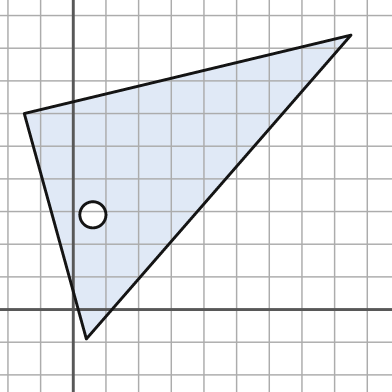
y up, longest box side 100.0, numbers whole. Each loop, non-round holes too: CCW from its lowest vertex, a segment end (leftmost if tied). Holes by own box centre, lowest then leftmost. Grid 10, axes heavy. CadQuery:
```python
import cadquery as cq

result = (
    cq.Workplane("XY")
    .moveTo(4.0, -9.0)
    .lineTo(85.0, 84.0)
    .lineTo(-15.0, 60.0)
    .close()
    .moveTo(6.0, 29.0)
    .circle(4.0)
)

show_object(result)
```